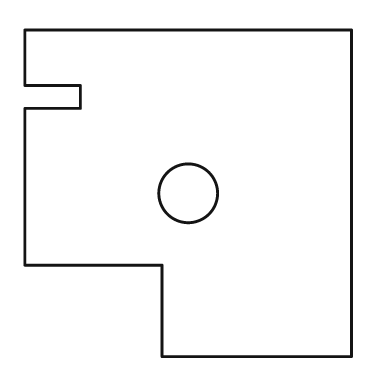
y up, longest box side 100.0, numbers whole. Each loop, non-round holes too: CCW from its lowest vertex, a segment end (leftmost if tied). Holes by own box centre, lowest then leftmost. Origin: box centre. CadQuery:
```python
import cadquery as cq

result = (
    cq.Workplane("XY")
    .moveTo(-8.0, -50.0)
    .lineTo(50.0, -50.0)
    .lineTo(50.0, 50.0)
    .lineTo(-50.0, 50.0)
    .lineTo(-50.0, 33.0)
    .lineTo(-33.0, 33.0)
    .lineTo(-33.0, 26.0)
    .lineTo(-50.0, 26.0)
    .lineTo(-50.0, -22.0)
    .lineTo(-8.0, -22.0)
    .close()
    .moveTo(0.0, 0.0)
    .circle(9.0)
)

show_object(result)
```